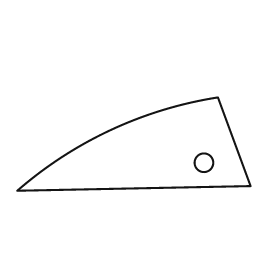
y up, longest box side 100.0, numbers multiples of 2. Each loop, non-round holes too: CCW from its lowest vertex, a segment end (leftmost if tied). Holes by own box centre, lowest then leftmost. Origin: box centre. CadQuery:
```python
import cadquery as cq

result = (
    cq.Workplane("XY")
    .moveTo(-50.0, -20.0)
    .lineTo(50.0, -18.0)
    .lineTo(36.0, 20.0)
    .threePointArc((-10.0, 6.0), (-50.0, -20.0))
    .close()
    .moveTo(30.0, -8.0)
    .circle(4.0)
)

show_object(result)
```